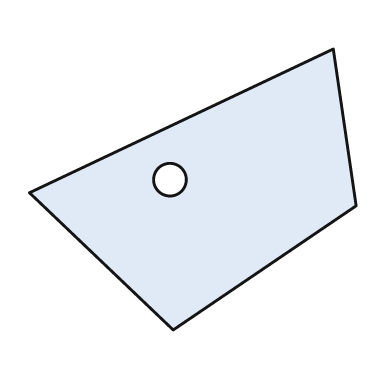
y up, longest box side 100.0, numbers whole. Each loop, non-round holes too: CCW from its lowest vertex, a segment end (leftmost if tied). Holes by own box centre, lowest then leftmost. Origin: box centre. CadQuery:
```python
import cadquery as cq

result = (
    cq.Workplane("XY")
    .moveTo(-6.0, -43.0)
    .lineTo(50.0, -5.0)
    .lineTo(43.0, 43.0)
    .lineTo(-50.0, -1.0)
    .close()
    .moveTo(-7.0, 3.0)
    .circle(5.0)
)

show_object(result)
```